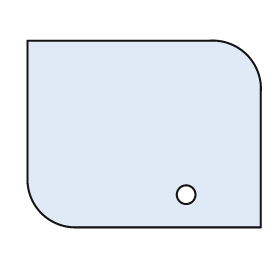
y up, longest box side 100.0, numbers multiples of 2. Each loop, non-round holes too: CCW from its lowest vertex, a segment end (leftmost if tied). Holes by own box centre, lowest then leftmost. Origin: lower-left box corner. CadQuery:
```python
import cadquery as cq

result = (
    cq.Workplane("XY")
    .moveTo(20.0, 0.0)
    .lineTo(100.0, 0.0)
    .lineTo(100.0, 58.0)
    .threePointArc((94.0, 74.0), (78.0, 80.0))
    .lineTo(0.0, 80.0)
    .lineTo(0.0, 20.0)
    .threePointArc((6.0, 6.0), (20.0, 0.0))
    .close()
    .moveTo(68.0, 14.0)
    .circle(4.0)
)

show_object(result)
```